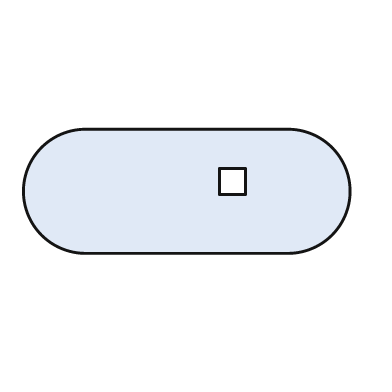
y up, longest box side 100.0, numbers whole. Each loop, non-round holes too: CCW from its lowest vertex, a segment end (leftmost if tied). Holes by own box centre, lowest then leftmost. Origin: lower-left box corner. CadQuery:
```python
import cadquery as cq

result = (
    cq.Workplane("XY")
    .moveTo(19.0, 0.0)
    .lineTo(81.0, 0.0)
    .threePointArc((100.0, 19.0), (81.0, 38.0))
    .lineTo(19.0, 38.0)
    .threePointArc((0.0, 19.0), (19.0, 0.0))
    .close()
    .moveTo(60.0, 18.0)
    .lineTo(68.0, 18.0)
    .lineTo(68.0, 26.0)
    .lineTo(60.0, 26.0)
    .close()
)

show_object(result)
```